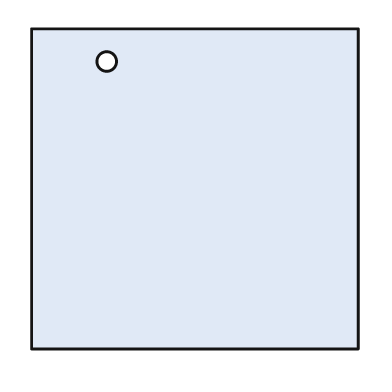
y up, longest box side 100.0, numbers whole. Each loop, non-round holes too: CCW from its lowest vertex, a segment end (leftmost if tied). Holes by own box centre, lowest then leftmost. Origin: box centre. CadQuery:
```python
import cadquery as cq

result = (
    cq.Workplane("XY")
    .moveTo(-50.0, -49.0)
    .lineTo(50.0, -49.0)
    .lineTo(50.0, 49.0)
    .lineTo(-50.0, 49.0)
    .close()
    .moveTo(-27.0, 39.0)
    .circle(3.0)
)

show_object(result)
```